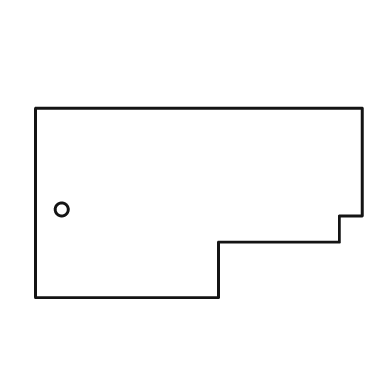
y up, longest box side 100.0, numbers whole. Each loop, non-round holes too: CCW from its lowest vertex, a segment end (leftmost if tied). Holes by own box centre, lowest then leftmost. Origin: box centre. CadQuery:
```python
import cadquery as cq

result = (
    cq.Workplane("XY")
    .moveTo(-50.0, -29.0)
    .lineTo(6.0, -29.0)
    .lineTo(6.0, -12.0)
    .lineTo(43.0, -12.0)
    .lineTo(43.0, -4.0)
    .lineTo(50.0, -4.0)
    .lineTo(50.0, 29.0)
    .lineTo(-50.0, 29.0)
    .close()
    .moveTo(-42.0, -2.0)
    .circle(2.0)
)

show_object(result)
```